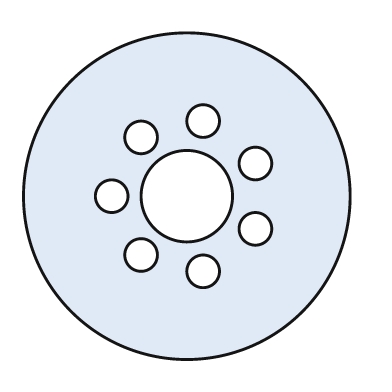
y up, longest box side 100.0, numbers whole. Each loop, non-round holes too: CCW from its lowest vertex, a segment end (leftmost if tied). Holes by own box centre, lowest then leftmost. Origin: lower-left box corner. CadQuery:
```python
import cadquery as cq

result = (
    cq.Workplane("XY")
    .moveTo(50.0, 50.0)
    .circle(50.0)
    .moveTo(55.0, 27.0)
    .circle(5.0)
    .moveTo(36.0, 32.0)
    .circle(5.0)
    .moveTo(71.0, 40.0)
    .circle(5.0)
    .moveTo(27.0, 50.0)
    .circle(5.0)
    .moveTo(50.0, 50.0)
    .circle(14.0)
    .moveTo(71.0, 60.0)
    .circle(5.0)
    .moveTo(36.0, 68.0)
    .circle(5.0)
    .moveTo(55.0, 73.0)
    .circle(5.0)
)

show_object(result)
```